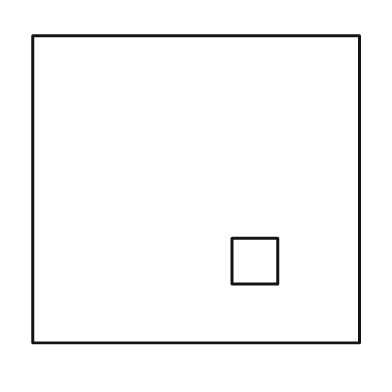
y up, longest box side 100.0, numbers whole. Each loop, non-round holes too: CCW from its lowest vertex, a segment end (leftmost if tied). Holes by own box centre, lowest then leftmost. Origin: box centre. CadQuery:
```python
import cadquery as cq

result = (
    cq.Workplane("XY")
    .moveTo(-50.0, -47.0)
    .lineTo(50.0, -47.0)
    .lineTo(50.0, 47.0)
    .lineTo(-50.0, 47.0)
    .close()
    .moveTo(11.0, -29.0)
    .lineTo(25.0, -29.0)
    .lineTo(25.0, -15.0)
    .lineTo(11.0, -15.0)
    .close()
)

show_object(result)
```